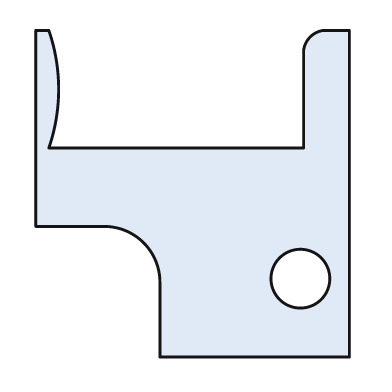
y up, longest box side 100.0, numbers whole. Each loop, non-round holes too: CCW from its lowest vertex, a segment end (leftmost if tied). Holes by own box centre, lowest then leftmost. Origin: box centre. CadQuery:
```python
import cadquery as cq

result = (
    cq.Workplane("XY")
    .moveTo(-10.0, -50.0)
    .lineTo(48.0, -50.0)
    .lineTo(48.0, 50.0)
    .lineTo(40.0, 50.0)
    .threePointArc((36.0, 48.0), (34.0, 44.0))
    .lineTo(34.0, 14.0)
    .lineTo(-44.0, 14.0)
    .threePointArc((-41.0, 32.0), (-44.0, 50.0))
    .lineTo(-48.0, 50.0)
    .lineTo(-48.0, -10.0)
    .lineTo(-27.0, -10.0)
    .threePointArc((-15.0, -15.0), (-10.0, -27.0))
    .close()
    .moveTo(33.0, -26.0)
    .circle(9.0)
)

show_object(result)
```